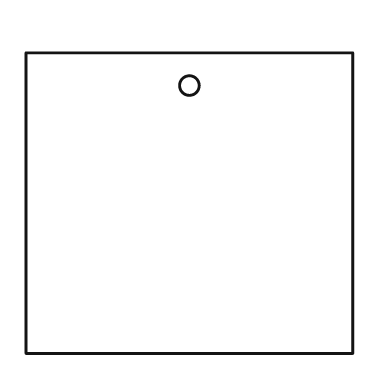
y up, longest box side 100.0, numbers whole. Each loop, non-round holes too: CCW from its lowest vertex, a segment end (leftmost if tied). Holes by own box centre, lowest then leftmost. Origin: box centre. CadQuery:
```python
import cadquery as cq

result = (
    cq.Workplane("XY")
    .moveTo(-50.0, -46.0)
    .lineTo(50.0, -46.0)
    .lineTo(50.0, 46.0)
    .lineTo(-50.0, 46.0)
    .close()
    .moveTo(0.0, 36.0)
    .circle(3.0)
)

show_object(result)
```